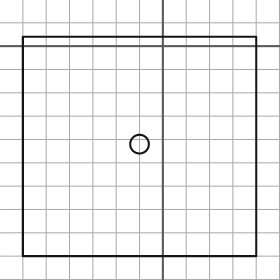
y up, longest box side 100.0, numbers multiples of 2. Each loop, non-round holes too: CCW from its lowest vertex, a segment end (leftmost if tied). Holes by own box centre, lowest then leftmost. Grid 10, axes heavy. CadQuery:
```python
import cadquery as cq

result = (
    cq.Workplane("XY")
    .moveTo(-60.0, -90.0)
    .lineTo(40.0, -90.0)
    .lineTo(40.0, 4.0)
    .lineTo(-60.0, 4.0)
    .close()
    .moveTo(-10.0, -42.0)
    .circle(4.0)
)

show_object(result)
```